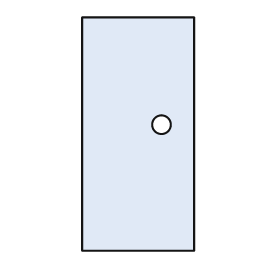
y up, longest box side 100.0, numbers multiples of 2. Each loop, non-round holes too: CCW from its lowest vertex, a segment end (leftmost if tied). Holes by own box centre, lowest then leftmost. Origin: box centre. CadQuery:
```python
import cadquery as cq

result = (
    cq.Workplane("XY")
    .moveTo(-24.0, -50.0)
    .lineTo(24.0, -50.0)
    .lineTo(24.0, 50.0)
    .lineTo(-24.0, 50.0)
    .close()
    .moveTo(10.0, 4.0)
    .circle(4.0)
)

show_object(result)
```